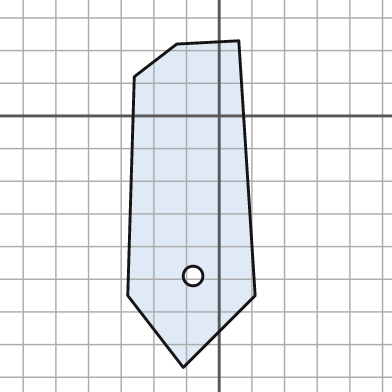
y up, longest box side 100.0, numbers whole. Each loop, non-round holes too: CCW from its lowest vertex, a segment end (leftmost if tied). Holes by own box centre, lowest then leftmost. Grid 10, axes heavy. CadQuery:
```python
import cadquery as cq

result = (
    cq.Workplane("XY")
    .moveTo(-11.0, -77.0)
    .lineTo(11.0, -55.0)
    .lineTo(6.0, 23.0)
    .lineTo(-13.0, 22.0)
    .lineTo(-26.0, 12.0)
    .lineTo(-28.0, -55.0)
    .close()
    .moveTo(-8.0, -49.0)
    .circle(3.0)
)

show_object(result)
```